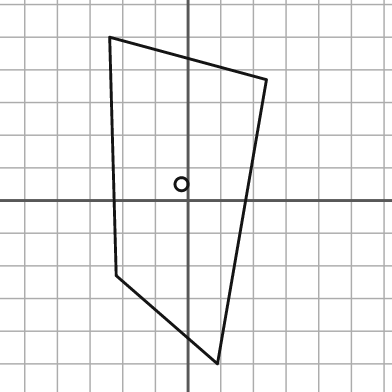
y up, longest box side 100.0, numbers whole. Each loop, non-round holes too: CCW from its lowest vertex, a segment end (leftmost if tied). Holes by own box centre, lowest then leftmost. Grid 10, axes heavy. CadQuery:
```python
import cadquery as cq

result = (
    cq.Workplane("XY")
    .moveTo(9.0, -50.0)
    .lineTo(24.0, 37.0)
    .lineTo(-24.0, 50.0)
    .lineTo(-22.0, -23.0)
    .close()
    .moveTo(-2.0, 5.0)
    .circle(2.0)
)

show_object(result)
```